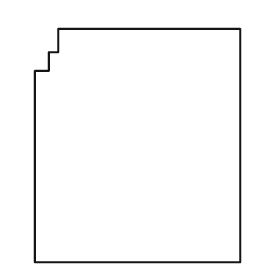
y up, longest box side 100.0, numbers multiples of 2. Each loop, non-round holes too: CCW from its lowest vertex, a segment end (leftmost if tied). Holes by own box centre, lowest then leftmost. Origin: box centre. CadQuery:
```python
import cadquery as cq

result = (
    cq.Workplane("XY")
    .moveTo(-44.0, -50.0)
    .lineTo(44.0, -50.0)
    .lineTo(44.0, 50.0)
    .lineTo(-34.0, 50.0)
    .lineTo(-34.0, 40.0)
    .lineTo(-38.0, 40.0)
    .lineTo(-38.0, 32.0)
    .lineTo(-44.0, 32.0)
    .close()
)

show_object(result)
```